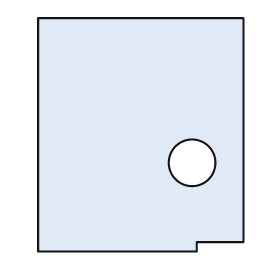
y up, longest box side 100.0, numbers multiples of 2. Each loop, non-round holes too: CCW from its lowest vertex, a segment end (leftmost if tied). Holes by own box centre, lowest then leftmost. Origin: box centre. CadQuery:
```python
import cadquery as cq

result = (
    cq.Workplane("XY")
    .moveTo(-44.0, -50.0)
    .lineTo(24.0, -50.0)
    .lineTo(24.0, -46.0)
    .lineTo(44.0, -46.0)
    .lineTo(44.0, 50.0)
    .lineTo(-44.0, 50.0)
    .close()
    .moveTo(22.0, -12.0)
    .circle(10.0)
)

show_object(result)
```